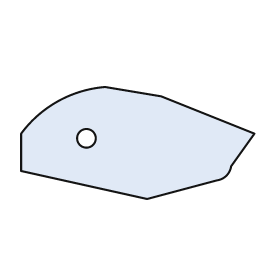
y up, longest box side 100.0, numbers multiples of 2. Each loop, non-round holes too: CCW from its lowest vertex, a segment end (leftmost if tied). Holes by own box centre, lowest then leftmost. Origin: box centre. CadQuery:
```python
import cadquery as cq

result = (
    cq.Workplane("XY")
    .moveTo(4.0, -24.0)
    .lineTo(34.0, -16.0)
    .threePointArc((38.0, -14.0), (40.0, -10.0))
    .lineTo(50.0, 4.0)
    .lineTo(10.0, 20.0)
    .lineTo(-14.0, 24.0)
    .threePointArc((-34.0, 18.0), (-50.0, 4.0))
    .lineTo(-50.0, -12.0)
    .close()
    .moveTo(-22.0, 2.0)
    .circle(4.0)
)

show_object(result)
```